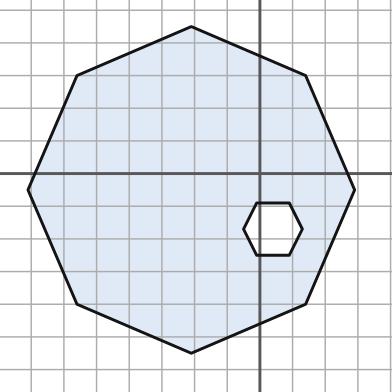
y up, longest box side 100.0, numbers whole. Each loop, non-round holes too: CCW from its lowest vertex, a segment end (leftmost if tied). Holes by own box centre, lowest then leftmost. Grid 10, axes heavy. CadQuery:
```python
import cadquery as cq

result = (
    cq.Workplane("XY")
    .moveTo(-21.0, -55.0)
    .lineTo(14.0, -40.0)
    .lineTo(29.0, -5.0)
    .lineTo(14.0, 30.0)
    .lineTo(-21.0, 45.0)
    .lineTo(-56.0, 30.0)
    .lineTo(-71.0, -5.0)
    .lineTo(-56.0, -40.0)
    .close()
    .moveTo(-1.0, -25.0)
    .lineTo(9.0, -25.0)
    .lineTo(13.0, -17.0)
    .lineTo(9.0, -9.0)
    .lineTo(-1.0, -9.0)
    .lineTo(-5.0, -17.0)
    .close()
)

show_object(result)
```